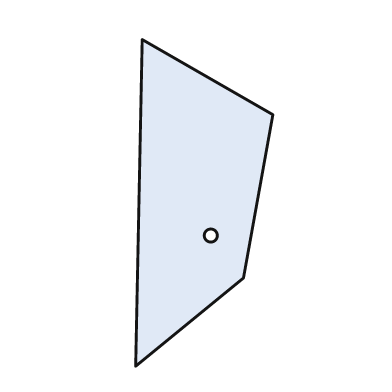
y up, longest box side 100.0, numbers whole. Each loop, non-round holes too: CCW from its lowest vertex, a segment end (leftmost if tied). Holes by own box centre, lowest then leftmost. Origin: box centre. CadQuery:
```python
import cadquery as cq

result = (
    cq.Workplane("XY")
    .moveTo(-21.0, -50.0)
    .lineTo(12.0, -23.0)
    .lineTo(21.0, 27.0)
    .lineTo(-19.0, 50.0)
    .close()
    .moveTo(2.0, -10.0)
    .circle(2.0)
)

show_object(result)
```